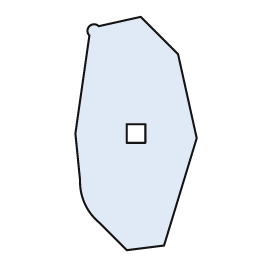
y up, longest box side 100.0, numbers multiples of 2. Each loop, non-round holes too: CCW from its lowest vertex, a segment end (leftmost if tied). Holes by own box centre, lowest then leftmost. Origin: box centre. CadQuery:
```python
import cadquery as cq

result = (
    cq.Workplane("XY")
    .moveTo(-4.0, -50.0)
    .lineTo(12.0, -48.0)
    .lineTo(26.0, -2.0)
    .lineTo(18.0, 34.0)
    .lineTo(2.0, 50.0)
    .lineTo(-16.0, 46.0)
    .threePointArc((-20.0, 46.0), (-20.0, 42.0))
    .lineTo(-26.0, 0.0)
    .lineTo(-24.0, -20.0)
    .threePointArc((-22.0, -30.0), (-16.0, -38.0))
    .close()
    .moveTo(-4.0, -4.0)
    .lineTo(4.0, -4.0)
    .lineTo(4.0, 4.0)
    .lineTo(-4.0, 4.0)
    .close()
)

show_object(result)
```